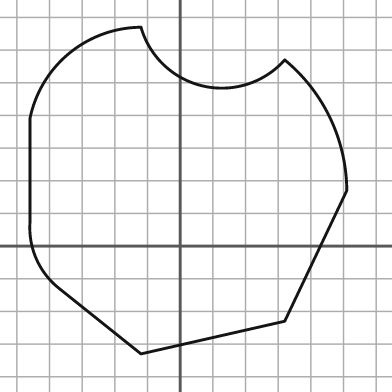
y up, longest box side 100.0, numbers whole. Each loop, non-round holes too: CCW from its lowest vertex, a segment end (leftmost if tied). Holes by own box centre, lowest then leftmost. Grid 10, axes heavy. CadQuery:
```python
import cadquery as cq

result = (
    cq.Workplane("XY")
    .moveTo(-12.0, -33.0)
    .lineTo(32.0, -23.0)
    .lineTo(51.0, 17.0)
    .threePointArc((46.0, 39.0), (32.0, 57.0))
    .threePointArc((7.0, 49.0), (-12.0, 67.0))
    .threePointArc((-34.0, 59.0), (-46.0, 39.0))
    .lineTo(-46.0, 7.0)
    .threePointArc((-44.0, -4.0), (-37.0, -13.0))
    .close()
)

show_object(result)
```